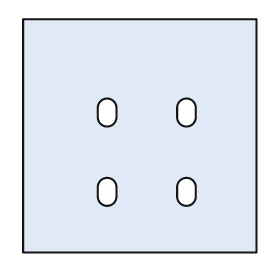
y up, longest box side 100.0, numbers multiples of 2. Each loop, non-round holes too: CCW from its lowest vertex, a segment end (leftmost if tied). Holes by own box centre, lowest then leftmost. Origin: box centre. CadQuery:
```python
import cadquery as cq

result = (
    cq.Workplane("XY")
    .moveTo(-50.0, -50.0)
    .lineTo(50.0, -50.0)
    .lineTo(50.0, 50.0)
    .lineTo(-50.0, 50.0)
    .close()
    .moveTo(-18.0, -26.0)
    .threePointArc((-14.0, -30.0), (-10.0, -26.0))
    .lineTo(-10.0, -22.0)
    .threePointArc((-14.0, -18.0), (-18.0, -22.0))
    .close()
    .moveTo(16.0, -26.0)
    .threePointArc((20.0, -30.0), (24.0, -26.0))
    .lineTo(24.0, -22.0)
    .threePointArc((20.0, -18.0), (16.0, -22.0))
    .close()
    .moveTo(-18.0, 8.0)
    .threePointArc((-14.0, 4.0), (-10.0, 8.0))
    .lineTo(-10.0, 12.0)
    .threePointArc((-14.0, 16.0), (-18.0, 12.0))
    .close()
    .moveTo(16.0, 8.0)
    .threePointArc((20.0, 4.0), (24.0, 8.0))
    .lineTo(24.0, 12.0)
    .threePointArc((20.0, 16.0), (16.0, 12.0))
    .close()
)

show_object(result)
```